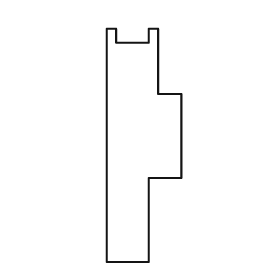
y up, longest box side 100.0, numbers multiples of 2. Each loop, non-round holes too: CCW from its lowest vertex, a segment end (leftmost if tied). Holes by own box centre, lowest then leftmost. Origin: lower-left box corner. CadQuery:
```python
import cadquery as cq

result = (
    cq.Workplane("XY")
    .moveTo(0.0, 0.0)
    .lineTo(18.0, 0.0)
    .lineTo(18.0, 36.0)
    .lineTo(32.0, 36.0)
    .lineTo(32.0, 72.0)
    .lineTo(22.0, 72.0)
    .lineTo(22.0, 100.0)
    .lineTo(18.0, 100.0)
    .lineTo(18.0, 94.0)
    .lineTo(4.0, 94.0)
    .lineTo(4.0, 100.0)
    .lineTo(0.0, 100.0)
    .close()
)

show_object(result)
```